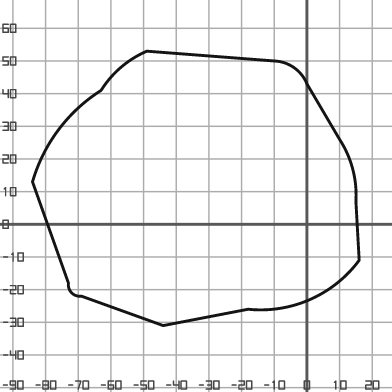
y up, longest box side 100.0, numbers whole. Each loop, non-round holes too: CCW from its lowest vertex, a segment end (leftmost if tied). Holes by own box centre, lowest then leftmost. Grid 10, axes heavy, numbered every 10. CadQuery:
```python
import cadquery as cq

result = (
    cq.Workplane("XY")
    .moveTo(-44.0, -31.0)
    .lineTo(-18.0, -26.0)
    .threePointArc((1.0, -23.0), (16.0, -11.0))
    .lineTo(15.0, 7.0)
    .threePointArc((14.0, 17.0), (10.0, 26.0))
    .lineTo(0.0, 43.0)
    .threePointArc((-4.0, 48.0), (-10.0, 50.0))
    .lineTo(-49.0, 53.0)
    .threePointArc((-57.0, 48.0), (-63.0, 41.0))
    .threePointArc((-76.0, 29.0), (-84.0, 13.0))
    .lineTo(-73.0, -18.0)
    .threePointArc((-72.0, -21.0), (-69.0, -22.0))
    .close()
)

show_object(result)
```